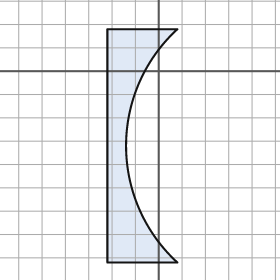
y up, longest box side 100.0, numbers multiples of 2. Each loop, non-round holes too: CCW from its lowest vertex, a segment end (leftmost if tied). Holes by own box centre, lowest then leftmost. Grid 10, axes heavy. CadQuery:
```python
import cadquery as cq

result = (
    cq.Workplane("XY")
    .moveTo(-22.0, -82.0)
    .lineTo(8.0, -82.0)
    .threePointArc((-14.0, -32.0), (8.0, 18.0))
    .lineTo(-22.0, 18.0)
    .close()
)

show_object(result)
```